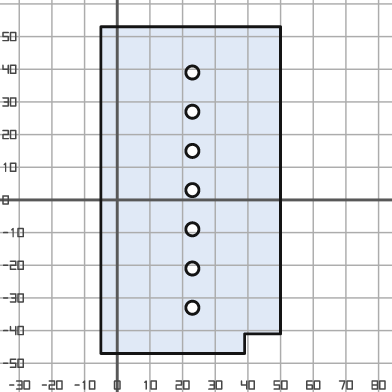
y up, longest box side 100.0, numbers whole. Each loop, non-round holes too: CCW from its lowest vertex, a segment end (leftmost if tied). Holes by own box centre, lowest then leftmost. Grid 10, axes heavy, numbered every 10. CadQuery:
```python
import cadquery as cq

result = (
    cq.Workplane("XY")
    .moveTo(-5.0, -47.0)
    .lineTo(39.0, -47.0)
    .lineTo(39.0, -41.0)
    .lineTo(50.0, -41.0)
    .lineTo(50.0, 53.0)
    .lineTo(-5.0, 53.0)
    .close()
    .moveTo(23.0, -33.0)
    .circle(2.0)
    .moveTo(23.0, -21.0)
    .circle(2.0)
    .moveTo(23.0, -9.0)
    .circle(2.0)
    .moveTo(23.0, 3.0)
    .circle(2.0)
    .moveTo(23.0, 15.0)
    .circle(2.0)
    .moveTo(23.0, 27.0)
    .circle(2.0)
    .moveTo(23.0, 39.0)
    .circle(2.0)
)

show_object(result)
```